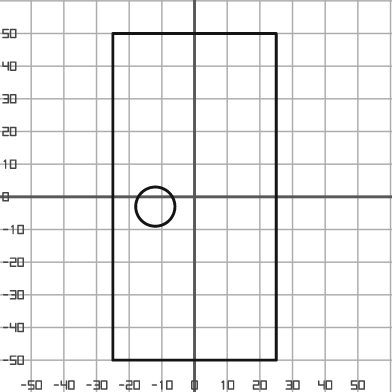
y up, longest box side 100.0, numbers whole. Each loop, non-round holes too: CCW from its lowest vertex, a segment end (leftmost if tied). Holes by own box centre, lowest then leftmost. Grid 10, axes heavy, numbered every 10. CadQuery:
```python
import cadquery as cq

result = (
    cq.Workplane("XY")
    .moveTo(-25.0, -50.0)
    .lineTo(25.0, -50.0)
    .lineTo(25.0, 50.0)
    .lineTo(-25.0, 50.0)
    .close()
    .moveTo(-12.0, -3.0)
    .circle(6.0)
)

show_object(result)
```